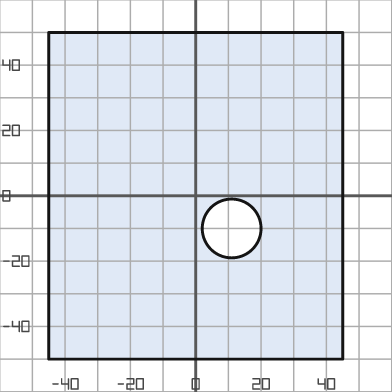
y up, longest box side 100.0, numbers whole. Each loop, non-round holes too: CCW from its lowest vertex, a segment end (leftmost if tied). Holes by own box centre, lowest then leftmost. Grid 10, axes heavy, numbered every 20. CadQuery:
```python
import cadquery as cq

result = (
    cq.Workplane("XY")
    .moveTo(-45.0, -50.0)
    .lineTo(45.0, -50.0)
    .lineTo(45.0, 50.0)
    .lineTo(-45.0, 50.0)
    .close()
    .moveTo(11.0, -10.0)
    .circle(9.0)
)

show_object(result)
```